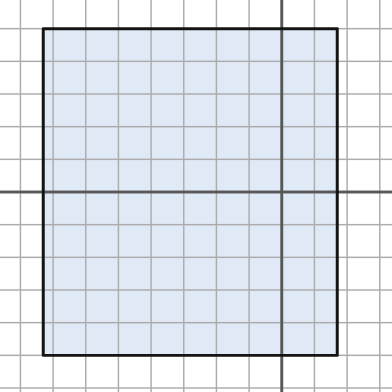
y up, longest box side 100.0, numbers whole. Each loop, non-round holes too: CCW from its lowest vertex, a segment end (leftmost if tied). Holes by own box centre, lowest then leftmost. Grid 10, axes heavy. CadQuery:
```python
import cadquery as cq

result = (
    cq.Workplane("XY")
    .moveTo(-73.0, -50.0)
    .lineTo(17.0, -50.0)
    .lineTo(17.0, 50.0)
    .lineTo(-73.0, 50.0)
    .close()
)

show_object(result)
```